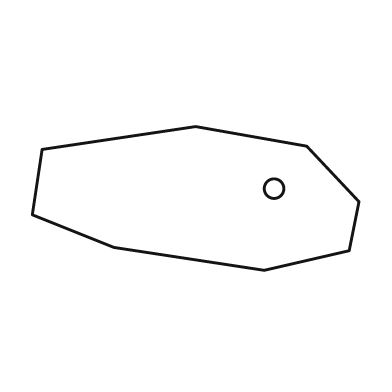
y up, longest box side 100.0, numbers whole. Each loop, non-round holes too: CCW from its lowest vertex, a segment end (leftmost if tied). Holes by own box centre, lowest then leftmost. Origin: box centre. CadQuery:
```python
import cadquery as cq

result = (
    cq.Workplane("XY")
    .moveTo(21.0, -22.0)
    .lineTo(47.0, -16.0)
    .lineTo(50.0, -1.0)
    .lineTo(34.0, 16.0)
    .lineTo(0.0, 22.0)
    .lineTo(-47.0, 15.0)
    .lineTo(-50.0, -5.0)
    .lineTo(-25.0, -15.0)
    .close()
    .moveTo(24.0, 3.0)
    .circle(3.0)
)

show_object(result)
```